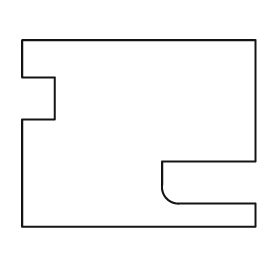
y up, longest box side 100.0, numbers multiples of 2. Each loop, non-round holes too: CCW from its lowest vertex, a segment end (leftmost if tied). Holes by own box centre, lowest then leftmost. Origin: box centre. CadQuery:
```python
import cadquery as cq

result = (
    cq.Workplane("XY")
    .moveTo(-50.0, -40.0)
    .lineTo(50.0, -40.0)
    .lineTo(50.0, -30.0)
    .lineTo(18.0, -30.0)
    .threePointArc((12.0, -28.0), (10.0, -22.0))
    .lineTo(10.0, -12.0)
    .lineTo(50.0, -12.0)
    .lineTo(50.0, 40.0)
    .lineTo(-50.0, 40.0)
    .lineTo(-50.0, 24.0)
    .lineTo(-36.0, 24.0)
    .lineTo(-36.0, 6.0)
    .lineTo(-50.0, 6.0)
    .close()
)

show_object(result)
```